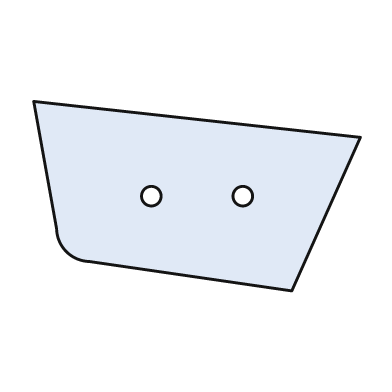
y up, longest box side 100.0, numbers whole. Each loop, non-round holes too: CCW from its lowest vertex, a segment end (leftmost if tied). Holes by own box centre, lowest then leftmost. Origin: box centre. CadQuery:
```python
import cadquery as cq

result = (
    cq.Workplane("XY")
    .moveTo(29.0, -29.0)
    .lineTo(50.0, 18.0)
    .lineTo(-50.0, 29.0)
    .lineTo(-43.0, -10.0)
    .threePointArc((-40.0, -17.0), (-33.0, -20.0))
    .close()
    .moveTo(-14.0, 0.0)
    .circle(3.0)
    .moveTo(14.0, 0.0)
    .circle(3.0)
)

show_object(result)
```